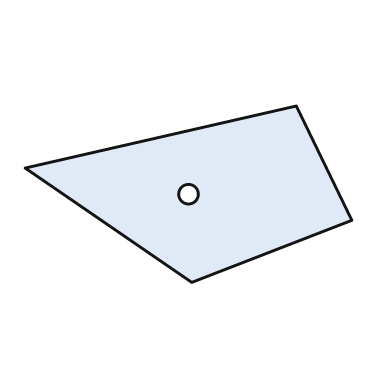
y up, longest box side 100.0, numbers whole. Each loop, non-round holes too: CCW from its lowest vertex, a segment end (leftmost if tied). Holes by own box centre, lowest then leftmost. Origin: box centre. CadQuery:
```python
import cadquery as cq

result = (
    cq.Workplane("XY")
    .moveTo(1.0, -27.0)
    .lineTo(50.0, -8.0)
    .lineTo(33.0, 27.0)
    .lineTo(-50.0, 8.0)
    .close()
    .moveTo(0.0, 0.0)
    .circle(3.0)
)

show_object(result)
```